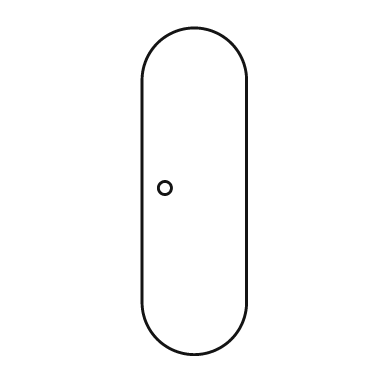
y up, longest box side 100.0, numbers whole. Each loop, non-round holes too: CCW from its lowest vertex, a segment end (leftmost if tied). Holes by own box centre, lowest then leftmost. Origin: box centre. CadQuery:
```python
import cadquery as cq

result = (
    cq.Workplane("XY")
    .moveTo(-16.0, -34.0)
    .threePointArc((0.0, -50.0), (16.0, -34.0))
    .lineTo(16.0, 34.0)
    .threePointArc((0.0, 50.0), (-16.0, 34.0))
    .close()
    .moveTo(-9.0, 1.0)
    .circle(2.0)
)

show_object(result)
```